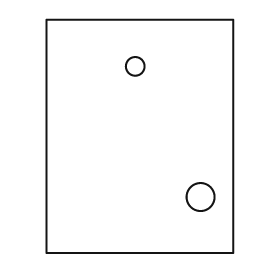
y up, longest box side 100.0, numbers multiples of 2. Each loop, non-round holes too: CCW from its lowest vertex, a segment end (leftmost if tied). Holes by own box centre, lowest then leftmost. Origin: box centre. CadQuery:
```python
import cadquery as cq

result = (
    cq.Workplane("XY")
    .moveTo(-40.0, -50.0)
    .lineTo(40.0, -50.0)
    .lineTo(40.0, 50.0)
    .lineTo(-40.0, 50.0)
    .close()
    .moveTo(26.0, -26.0)
    .circle(6.0)
    .moveTo(-2.0, 30.0)
    .circle(4.0)
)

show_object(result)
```